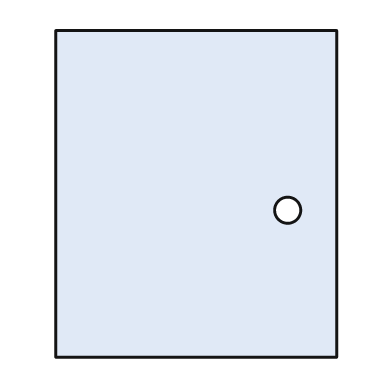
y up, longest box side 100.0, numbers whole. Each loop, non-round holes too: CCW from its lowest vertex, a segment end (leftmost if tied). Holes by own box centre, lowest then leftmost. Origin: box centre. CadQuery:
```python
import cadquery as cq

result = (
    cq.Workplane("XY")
    .moveTo(-43.0, -50.0)
    .lineTo(43.0, -50.0)
    .lineTo(43.0, 50.0)
    .lineTo(-43.0, 50.0)
    .close()
    .moveTo(28.0, -5.0)
    .circle(4.0)
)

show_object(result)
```